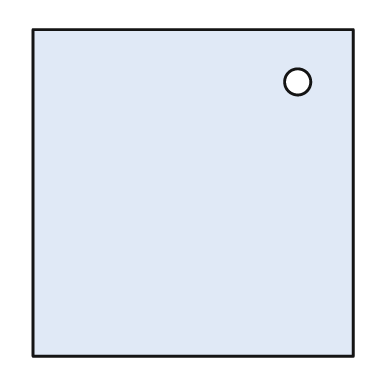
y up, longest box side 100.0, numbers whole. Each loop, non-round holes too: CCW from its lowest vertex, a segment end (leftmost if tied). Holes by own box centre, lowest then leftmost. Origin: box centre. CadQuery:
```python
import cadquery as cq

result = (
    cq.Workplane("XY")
    .moveTo(-49.0, -50.0)
    .lineTo(49.0, -50.0)
    .lineTo(49.0, 50.0)
    .lineTo(-49.0, 50.0)
    .close()
    .moveTo(32.0, 34.0)
    .circle(4.0)
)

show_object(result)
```